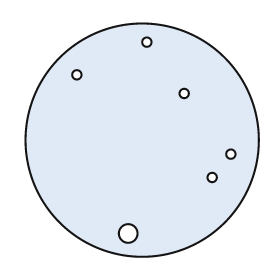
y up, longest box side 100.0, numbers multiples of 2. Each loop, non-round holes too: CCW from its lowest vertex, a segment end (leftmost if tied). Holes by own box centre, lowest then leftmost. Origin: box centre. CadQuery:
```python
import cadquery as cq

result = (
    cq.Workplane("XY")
    .moveTo(0.0, 0.0)
    .circle(50.0)
    .moveTo(-6.0, -40.0)
    .circle(4.0)
    .moveTo(30.0, -16.0)
    .circle(2.0)
    .moveTo(38.0, -6.0)
    .circle(2.0)
    .moveTo(18.0, 20.0)
    .circle(2.0)
    .moveTo(-28.0, 28.0)
    .circle(2.0)
    .moveTo(2.0, 42.0)
    .circle(2.0)
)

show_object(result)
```